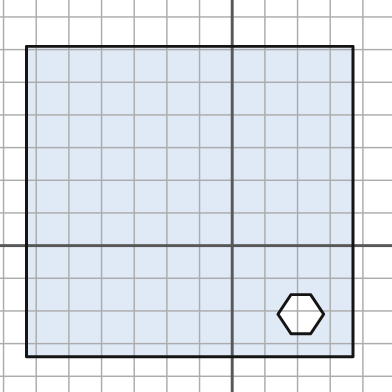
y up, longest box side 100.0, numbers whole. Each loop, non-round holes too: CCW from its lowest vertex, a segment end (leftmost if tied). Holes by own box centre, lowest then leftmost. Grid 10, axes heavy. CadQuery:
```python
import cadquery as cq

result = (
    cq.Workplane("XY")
    .moveTo(-63.0, -34.0)
    .lineTo(37.0, -34.0)
    .lineTo(37.0, 61.0)
    .lineTo(-63.0, 61.0)
    .close()
    .moveTo(18.0, -27.0)
    .lineTo(24.0, -27.0)
    .lineTo(28.0, -21.0)
    .lineTo(24.0, -15.0)
    .lineTo(18.0, -15.0)
    .lineTo(14.0, -21.0)
    .close()
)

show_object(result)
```